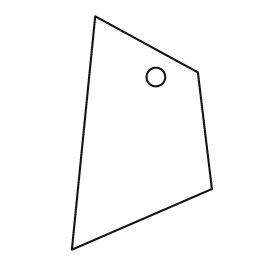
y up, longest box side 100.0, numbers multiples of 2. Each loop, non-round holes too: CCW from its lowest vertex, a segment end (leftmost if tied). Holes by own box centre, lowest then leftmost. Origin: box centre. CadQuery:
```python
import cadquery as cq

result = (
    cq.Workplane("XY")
    .moveTo(-30.0, -50.0)
    .lineTo(30.0, -24.0)
    .lineTo(24.0, 26.0)
    .lineTo(-20.0, 50.0)
    .close()
    .moveTo(6.0, 24.0)
    .circle(4.0)
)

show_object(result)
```